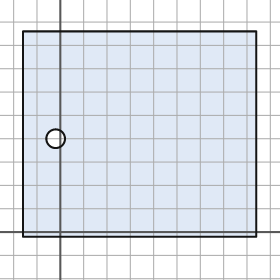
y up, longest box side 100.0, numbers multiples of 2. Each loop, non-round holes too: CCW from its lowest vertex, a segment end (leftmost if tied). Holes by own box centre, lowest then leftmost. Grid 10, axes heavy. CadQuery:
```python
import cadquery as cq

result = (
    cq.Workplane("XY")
    .moveTo(-16.0, -2.0)
    .lineTo(84.0, -2.0)
    .lineTo(84.0, 86.0)
    .lineTo(-16.0, 86.0)
    .close()
    .moveTo(-2.0, 40.0)
    .circle(4.0)
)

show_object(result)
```